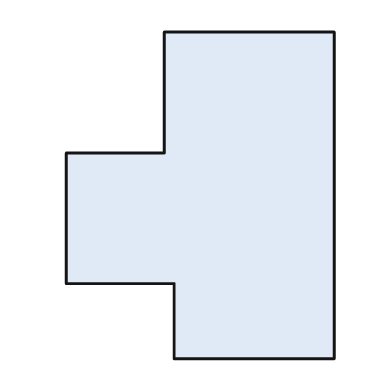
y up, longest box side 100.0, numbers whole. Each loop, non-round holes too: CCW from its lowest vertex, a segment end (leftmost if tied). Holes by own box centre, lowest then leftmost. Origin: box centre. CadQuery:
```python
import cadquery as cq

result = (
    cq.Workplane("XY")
    .moveTo(-8.0, -50.0)
    .lineTo(41.0, -50.0)
    .lineTo(41.0, 50.0)
    .lineTo(-11.0, 50.0)
    .lineTo(-11.0, 13.0)
    .lineTo(-41.0, 13.0)
    .lineTo(-41.0, -27.0)
    .lineTo(-8.0, -27.0)
    .close()
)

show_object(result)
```